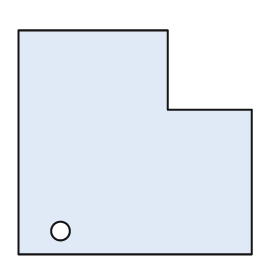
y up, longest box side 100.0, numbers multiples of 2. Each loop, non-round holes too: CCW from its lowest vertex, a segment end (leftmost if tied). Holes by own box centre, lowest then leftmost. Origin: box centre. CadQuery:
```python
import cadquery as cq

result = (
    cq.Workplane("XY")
    .moveTo(-50.0, -48.0)
    .lineTo(50.0, -48.0)
    .lineTo(50.0, 14.0)
    .lineTo(14.0, 14.0)
    .lineTo(14.0, 48.0)
    .lineTo(-50.0, 48.0)
    .close()
    .moveTo(-32.0, -38.0)
    .circle(4.0)
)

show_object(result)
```